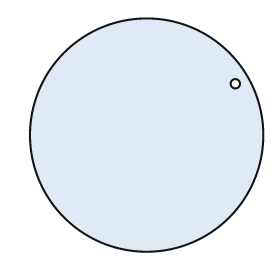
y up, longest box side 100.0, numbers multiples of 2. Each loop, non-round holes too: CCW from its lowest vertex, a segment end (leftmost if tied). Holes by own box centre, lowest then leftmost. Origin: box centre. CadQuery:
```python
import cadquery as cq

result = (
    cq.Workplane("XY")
    .moveTo(0.0, 0.0)
    .circle(50.0)
    .moveTo(38.0, 22.0)
    .circle(2.0)
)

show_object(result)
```